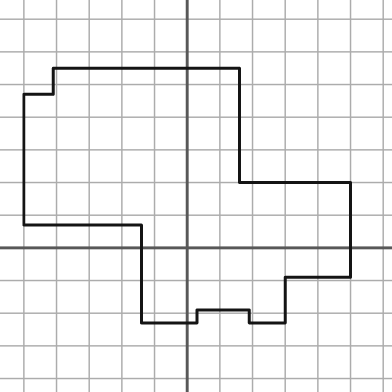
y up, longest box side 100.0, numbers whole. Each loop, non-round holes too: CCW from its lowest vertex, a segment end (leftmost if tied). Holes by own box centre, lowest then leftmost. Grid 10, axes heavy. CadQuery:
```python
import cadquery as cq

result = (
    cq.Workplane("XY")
    .moveTo(-14.0, -23.0)
    .lineTo(3.0, -23.0)
    .lineTo(3.0, -19.0)
    .lineTo(19.0, -19.0)
    .lineTo(19.0, -23.0)
    .lineTo(30.0, -23.0)
    .lineTo(30.0, -9.0)
    .lineTo(50.0, -9.0)
    .lineTo(50.0, 20.0)
    .lineTo(16.0, 20.0)
    .lineTo(16.0, 55.0)
    .lineTo(-41.0, 55.0)
    .lineTo(-41.0, 47.0)
    .lineTo(-50.0, 47.0)
    .lineTo(-50.0, 7.0)
    .lineTo(-14.0, 7.0)
    .close()
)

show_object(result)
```